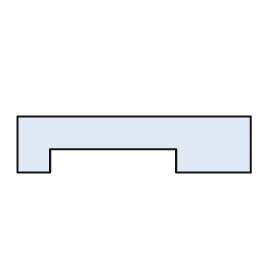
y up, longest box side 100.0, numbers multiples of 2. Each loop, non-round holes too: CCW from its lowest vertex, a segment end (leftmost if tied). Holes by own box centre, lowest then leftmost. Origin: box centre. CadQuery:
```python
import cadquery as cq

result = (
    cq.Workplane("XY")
    .moveTo(-50.0, -12.0)
    .lineTo(-36.0, -12.0)
    .lineTo(-36.0, -2.0)
    .lineTo(18.0, -2.0)
    .lineTo(18.0, -12.0)
    .lineTo(50.0, -12.0)
    .lineTo(50.0, 12.0)
    .lineTo(-50.0, 12.0)
    .close()
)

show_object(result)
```